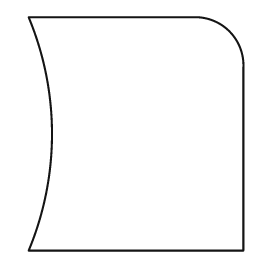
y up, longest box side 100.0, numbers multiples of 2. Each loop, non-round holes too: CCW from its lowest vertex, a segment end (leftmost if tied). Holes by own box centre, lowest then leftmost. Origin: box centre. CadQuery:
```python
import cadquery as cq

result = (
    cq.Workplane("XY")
    .moveTo(-46.0, -50.0)
    .lineTo(46.0, -50.0)
    .lineTo(46.0, 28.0)
    .threePointArc((40.0, 44.0), (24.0, 50.0))
    .lineTo(-46.0, 50.0)
    .threePointArc((-36.0, 0.0), (-46.0, -50.0))
    .close()
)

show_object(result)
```